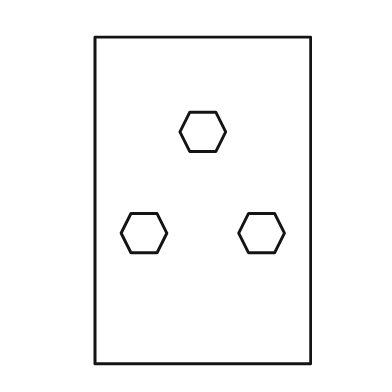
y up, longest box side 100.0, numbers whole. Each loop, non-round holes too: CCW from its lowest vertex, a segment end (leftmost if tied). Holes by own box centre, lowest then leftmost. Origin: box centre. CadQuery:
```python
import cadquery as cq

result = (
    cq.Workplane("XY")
    .moveTo(-33.0, -50.0)
    .lineTo(33.0, -50.0)
    .lineTo(33.0, 50.0)
    .lineTo(-33.0, 50.0)
    .close()
    .moveTo(-22.0, -16.0)
    .lineTo(-14.0, -16.0)
    .lineTo(-11.0, -10.0)
    .lineTo(-14.0, -4.0)
    .lineTo(-22.0, -4.0)
    .lineTo(-25.0, -10.0)
    .close()
    .moveTo(14.0, -16.0)
    .lineTo(22.0, -16.0)
    .lineTo(25.0, -10.0)
    .lineTo(22.0, -4.0)
    .lineTo(14.0, -4.0)
    .lineTo(11.0, -10.0)
    .close()
    .moveTo(-4.0, 15.0)
    .lineTo(4.0, 15.0)
    .lineTo(7.0, 21.0)
    .lineTo(4.0, 27.0)
    .lineTo(-4.0, 27.0)
    .lineTo(-7.0, 21.0)
    .close()
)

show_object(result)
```